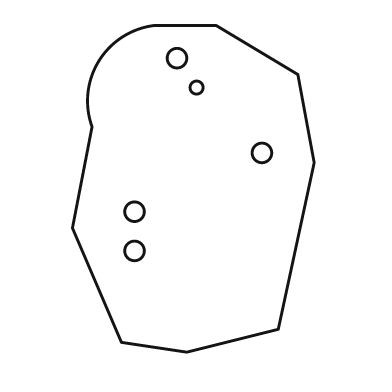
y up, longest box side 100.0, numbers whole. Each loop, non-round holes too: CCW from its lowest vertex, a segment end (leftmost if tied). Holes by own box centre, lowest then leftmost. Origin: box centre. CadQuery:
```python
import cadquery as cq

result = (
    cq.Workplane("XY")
    .moveTo(-2.0, -50.0)
    .lineTo(26.0, -43.0)
    .lineTo(37.0, 8.0)
    .lineTo(32.0, 35.0)
    .lineTo(7.0, 50.0)
    .lineTo(-12.0, 50.0)
    .threePointArc((-29.0, 39.0), (-31.0, 19.0))
    .lineTo(-37.0, -12.0)
    .lineTo(-22.0, -47.0)
    .close()
    .moveTo(-18.0, -19.0)
    .circle(3.0)
    .moveTo(-18.0, -7.0)
    .circle(3.0)
    .moveTo(21.0, 11.0)
    .circle(3.0)
    .moveTo(1.0, 31.0)
    .circle(2.0)
    .moveTo(-5.0, 40.0)
    .circle(3.0)
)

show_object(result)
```